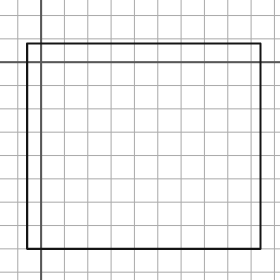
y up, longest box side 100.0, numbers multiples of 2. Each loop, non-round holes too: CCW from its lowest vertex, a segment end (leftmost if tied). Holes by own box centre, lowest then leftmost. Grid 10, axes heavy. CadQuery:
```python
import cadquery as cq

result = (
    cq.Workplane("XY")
    .moveTo(-6.0, -80.0)
    .lineTo(94.0, -80.0)
    .lineTo(94.0, 8.0)
    .lineTo(-6.0, 8.0)
    .close()
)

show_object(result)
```